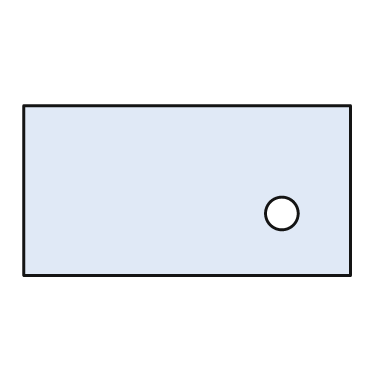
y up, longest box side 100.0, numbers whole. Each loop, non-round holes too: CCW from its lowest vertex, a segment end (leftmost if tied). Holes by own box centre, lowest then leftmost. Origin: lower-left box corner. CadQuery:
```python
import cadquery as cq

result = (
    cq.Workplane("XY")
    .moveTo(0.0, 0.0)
    .lineTo(100.0, 0.0)
    .lineTo(100.0, 52.0)
    .lineTo(0.0, 52.0)
    .close()
    .moveTo(79.0, 19.0)
    .circle(5.0)
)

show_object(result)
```